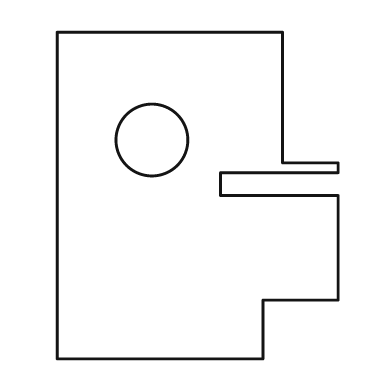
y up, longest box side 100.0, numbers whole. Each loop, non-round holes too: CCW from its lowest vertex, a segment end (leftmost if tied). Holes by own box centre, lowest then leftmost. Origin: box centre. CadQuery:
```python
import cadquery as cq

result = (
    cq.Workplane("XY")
    .moveTo(-43.0, -50.0)
    .lineTo(20.0, -50.0)
    .lineTo(20.0, -32.0)
    .lineTo(43.0, -32.0)
    .lineTo(43.0, 0.0)
    .lineTo(7.0, 0.0)
    .lineTo(7.0, 7.0)
    .lineTo(43.0, 7.0)
    .lineTo(43.0, 10.0)
    .lineTo(26.0, 10.0)
    .lineTo(26.0, 50.0)
    .lineTo(-43.0, 50.0)
    .close()
    .moveTo(-14.0, 17.0)
    .circle(11.0)
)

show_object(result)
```